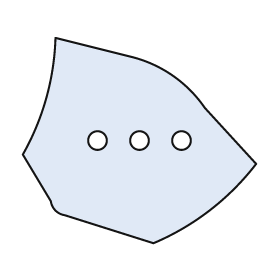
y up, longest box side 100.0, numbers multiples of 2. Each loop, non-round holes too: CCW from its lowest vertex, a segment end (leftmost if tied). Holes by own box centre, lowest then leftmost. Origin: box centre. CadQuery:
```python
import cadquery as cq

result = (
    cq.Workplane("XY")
    .moveTo(6.0, -44.0)
    .threePointArc((30.0, -30.0), (50.0, -10.0))
    .lineTo(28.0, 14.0)
    .threePointArc((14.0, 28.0), (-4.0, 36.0))
    .lineTo(-36.0, 44.0)
    .threePointArc((-40.0, 18.0), (-50.0, -6.0))
    .lineTo(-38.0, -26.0)
    .threePointArc((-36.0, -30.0), (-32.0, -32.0))
    .close()
    .moveTo(-18.0, 0.0)
    .circle(4.0)
    .moveTo(0.0, 0.0)
    .circle(4.0)
    .moveTo(18.0, 0.0)
    .circle(4.0)
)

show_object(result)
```